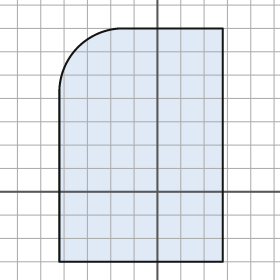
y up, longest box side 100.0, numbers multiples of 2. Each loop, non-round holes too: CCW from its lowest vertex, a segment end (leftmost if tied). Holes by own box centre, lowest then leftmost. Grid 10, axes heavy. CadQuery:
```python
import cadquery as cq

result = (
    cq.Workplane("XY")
    .moveTo(-42.0, -30.0)
    .lineTo(28.0, -30.0)
    .lineTo(28.0, 70.0)
    .lineTo(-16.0, 70.0)
    .threePointArc((-34.0, 62.0), (-42.0, 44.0))
    .close()
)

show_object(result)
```